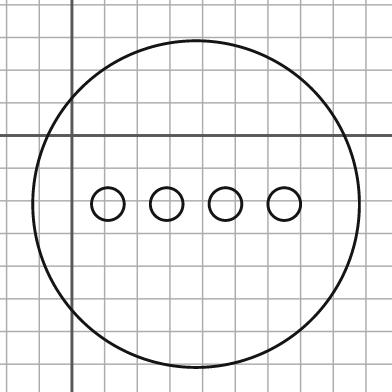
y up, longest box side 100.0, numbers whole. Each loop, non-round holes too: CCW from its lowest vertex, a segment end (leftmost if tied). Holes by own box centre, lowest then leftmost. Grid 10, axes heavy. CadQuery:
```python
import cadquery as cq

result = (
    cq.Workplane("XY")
    .moveTo(38.0, -21.0)
    .circle(50.0)
    .moveTo(11.0, -21.0)
    .circle(5.0)
    .moveTo(29.0, -21.0)
    .circle(5.0)
    .moveTo(47.0, -21.0)
    .circle(5.0)
    .moveTo(65.0, -21.0)
    .circle(5.0)
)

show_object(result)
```